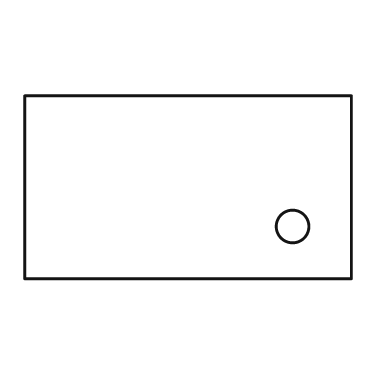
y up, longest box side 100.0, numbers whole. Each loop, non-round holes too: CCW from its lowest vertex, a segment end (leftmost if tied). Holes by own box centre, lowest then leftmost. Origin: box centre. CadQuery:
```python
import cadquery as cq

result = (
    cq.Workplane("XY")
    .moveTo(-50.0, -28.0)
    .lineTo(50.0, -28.0)
    .lineTo(50.0, 28.0)
    .lineTo(-50.0, 28.0)
    .close()
    .moveTo(32.0, -12.0)
    .circle(5.0)
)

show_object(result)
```